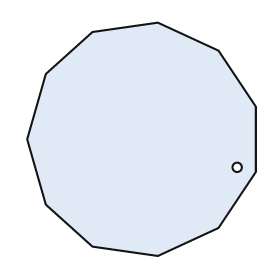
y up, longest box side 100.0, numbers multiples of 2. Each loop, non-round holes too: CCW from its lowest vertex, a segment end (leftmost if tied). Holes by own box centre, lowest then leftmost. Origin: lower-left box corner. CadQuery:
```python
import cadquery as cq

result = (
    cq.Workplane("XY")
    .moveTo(56.0, 0.0)
    .lineTo(82.0, 12.0)
    .lineTo(98.0, 36.0)
    .lineTo(98.0, 64.0)
    .lineTo(82.0, 88.0)
    .lineTo(56.0, 100.0)
    .lineTo(28.0, 96.0)
    .lineTo(8.0, 78.0)
    .lineTo(0.0, 50.0)
    .lineTo(8.0, 22.0)
    .lineTo(28.0, 4.0)
    .close()
    .moveTo(90.0, 38.0)
    .circle(2.0)
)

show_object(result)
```